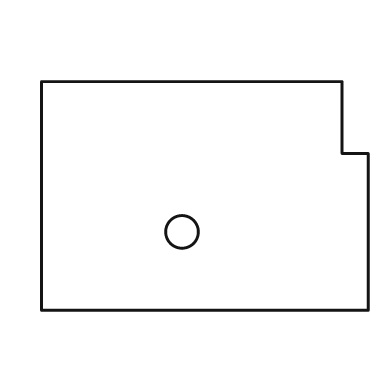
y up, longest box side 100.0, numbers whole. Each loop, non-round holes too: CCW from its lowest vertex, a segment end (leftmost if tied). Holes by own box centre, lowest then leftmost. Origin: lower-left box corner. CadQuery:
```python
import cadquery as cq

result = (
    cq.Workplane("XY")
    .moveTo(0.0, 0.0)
    .lineTo(100.0, 0.0)
    .lineTo(100.0, 48.0)
    .lineTo(92.0, 48.0)
    .lineTo(92.0, 70.0)
    .lineTo(0.0, 70.0)
    .close()
    .moveTo(43.0, 24.0)
    .circle(5.0)
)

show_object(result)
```